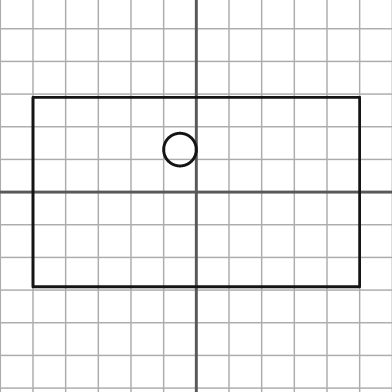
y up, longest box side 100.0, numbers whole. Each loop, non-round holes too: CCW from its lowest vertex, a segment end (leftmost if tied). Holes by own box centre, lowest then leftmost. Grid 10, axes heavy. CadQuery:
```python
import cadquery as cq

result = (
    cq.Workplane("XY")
    .moveTo(-50.0, -29.0)
    .lineTo(50.0, -29.0)
    .lineTo(50.0, 29.0)
    .lineTo(-50.0, 29.0)
    .close()
    .moveTo(-5.0, 13.0)
    .circle(5.0)
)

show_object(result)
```